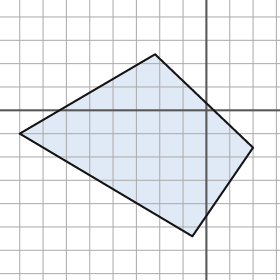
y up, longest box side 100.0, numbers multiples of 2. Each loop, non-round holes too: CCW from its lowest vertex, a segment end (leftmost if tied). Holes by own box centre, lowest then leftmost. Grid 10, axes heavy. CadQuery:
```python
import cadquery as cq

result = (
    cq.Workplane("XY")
    .moveTo(-6.0, -54.0)
    .lineTo(20.0, -16.0)
    .lineTo(-22.0, 24.0)
    .lineTo(-80.0, -10.0)
    .close()
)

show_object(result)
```